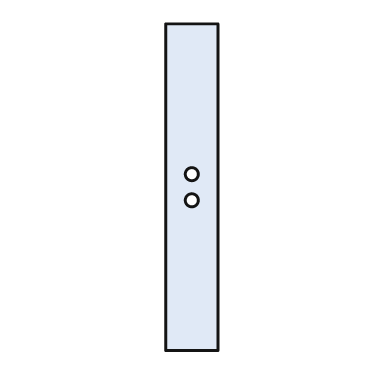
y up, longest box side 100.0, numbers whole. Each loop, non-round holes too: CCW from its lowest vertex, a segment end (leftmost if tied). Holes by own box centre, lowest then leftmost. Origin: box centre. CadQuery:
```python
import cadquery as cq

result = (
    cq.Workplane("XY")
    .moveTo(-8.0, -50.0)
    .lineTo(8.0, -50.0)
    .lineTo(8.0, 50.0)
    .lineTo(-8.0, 50.0)
    .close()
    .moveTo(0.0, -4.0)
    .circle(2.0)
    .moveTo(0.0, 4.0)
    .circle(2.0)
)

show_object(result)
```